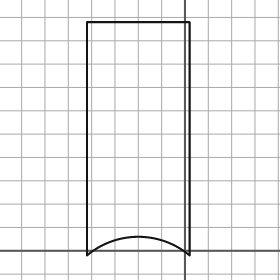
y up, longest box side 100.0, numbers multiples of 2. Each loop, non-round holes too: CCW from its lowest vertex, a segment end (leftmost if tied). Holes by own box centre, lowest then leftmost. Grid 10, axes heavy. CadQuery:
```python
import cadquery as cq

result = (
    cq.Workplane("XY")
    .moveTo(-42.0, -2.0)
    .threePointArc((-20.0, 6.0), (2.0, -2.0))
    .lineTo(2.0, 98.0)
    .lineTo(-42.0, 98.0)
    .close()
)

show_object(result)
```